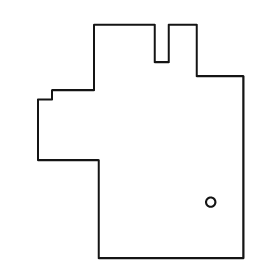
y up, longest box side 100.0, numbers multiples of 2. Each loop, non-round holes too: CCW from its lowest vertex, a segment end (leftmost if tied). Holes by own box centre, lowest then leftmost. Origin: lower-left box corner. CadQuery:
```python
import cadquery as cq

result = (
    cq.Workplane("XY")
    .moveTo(26.0, 0.0)
    .lineTo(88.0, 0.0)
    .lineTo(88.0, 78.0)
    .lineTo(68.0, 78.0)
    .lineTo(68.0, 100.0)
    .lineTo(56.0, 100.0)
    .lineTo(56.0, 84.0)
    .lineTo(50.0, 84.0)
    .lineTo(50.0, 100.0)
    .lineTo(24.0, 100.0)
    .lineTo(24.0, 72.0)
    .lineTo(6.0, 72.0)
    .lineTo(6.0, 68.0)
    .lineTo(0.0, 68.0)
    .lineTo(0.0, 42.0)
    .lineTo(26.0, 42.0)
    .close()
    .moveTo(74.0, 24.0)
    .circle(2.0)
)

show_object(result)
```